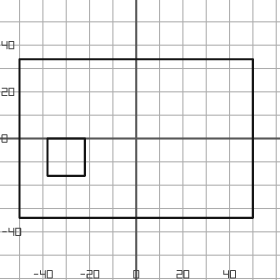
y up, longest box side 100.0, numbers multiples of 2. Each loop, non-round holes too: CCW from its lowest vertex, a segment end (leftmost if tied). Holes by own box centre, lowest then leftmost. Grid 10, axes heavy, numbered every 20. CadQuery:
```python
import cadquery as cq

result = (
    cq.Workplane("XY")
    .moveTo(-50.0, -34.0)
    .lineTo(50.0, -34.0)
    .lineTo(50.0, 34.0)
    .lineTo(-50.0, 34.0)
    .close()
    .moveTo(-38.0, -16.0)
    .lineTo(-22.0, -16.0)
    .lineTo(-22.0, 0.0)
    .lineTo(-38.0, 0.0)
    .close()
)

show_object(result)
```